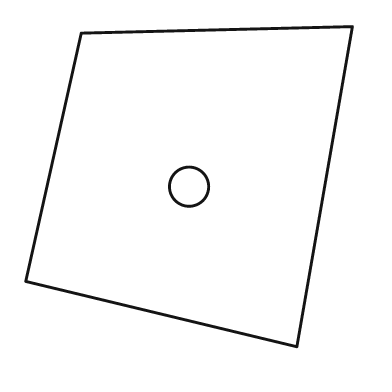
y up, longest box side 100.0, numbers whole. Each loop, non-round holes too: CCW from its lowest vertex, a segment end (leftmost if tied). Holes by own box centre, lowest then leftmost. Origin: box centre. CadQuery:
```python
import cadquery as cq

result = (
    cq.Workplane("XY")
    .moveTo(33.0, -49.0)
    .lineTo(50.0, 49.0)
    .lineTo(-33.0, 47.0)
    .lineTo(-50.0, -29.0)
    .close()
    .moveTo(0.0, 0.0)
    .circle(6.0)
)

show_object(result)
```